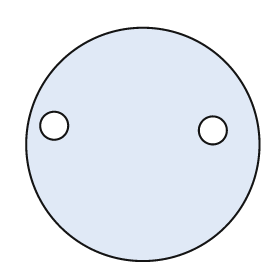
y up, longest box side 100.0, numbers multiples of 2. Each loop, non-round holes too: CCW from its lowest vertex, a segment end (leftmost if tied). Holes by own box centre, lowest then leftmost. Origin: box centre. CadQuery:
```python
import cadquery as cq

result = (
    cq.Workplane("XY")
    .moveTo(0.0, 0.0)
    .circle(50.0)
    .moveTo(30.0, 6.0)
    .circle(6.0)
    .moveTo(-38.0, 8.0)
    .circle(6.0)
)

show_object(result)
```